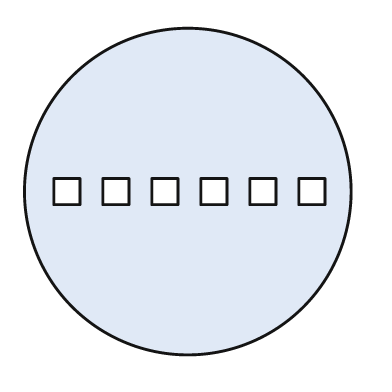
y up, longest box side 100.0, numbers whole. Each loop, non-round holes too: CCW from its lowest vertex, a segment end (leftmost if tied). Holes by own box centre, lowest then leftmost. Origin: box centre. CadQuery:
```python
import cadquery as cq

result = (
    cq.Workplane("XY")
    .moveTo(0.0, 0.0)
    .circle(50.0)
    .moveTo(-41.0, -4.0)
    .lineTo(-33.0, -4.0)
    .lineTo(-33.0, 4.0)
    .lineTo(-41.0, 4.0)
    .close()
    .moveTo(-26.0, -4.0)
    .lineTo(-18.0, -4.0)
    .lineTo(-18.0, 4.0)
    .lineTo(-26.0, 4.0)
    .close()
    .moveTo(-11.0, -4.0)
    .lineTo(-3.0, -4.0)
    .lineTo(-3.0, 4.0)
    .lineTo(-11.0, 4.0)
    .close()
    .moveTo(4.0, -4.0)
    .lineTo(12.0, -4.0)
    .lineTo(12.0, 4.0)
    .lineTo(4.0, 4.0)
    .close()
    .moveTo(19.0, -4.0)
    .lineTo(27.0, -4.0)
    .lineTo(27.0, 4.0)
    .lineTo(19.0, 4.0)
    .close()
    .moveTo(34.0, -4.0)
    .lineTo(42.0, -4.0)
    .lineTo(42.0, 4.0)
    .lineTo(34.0, 4.0)
    .close()
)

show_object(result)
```